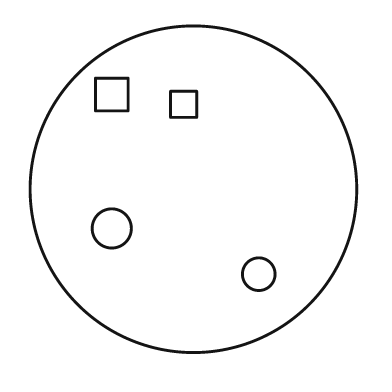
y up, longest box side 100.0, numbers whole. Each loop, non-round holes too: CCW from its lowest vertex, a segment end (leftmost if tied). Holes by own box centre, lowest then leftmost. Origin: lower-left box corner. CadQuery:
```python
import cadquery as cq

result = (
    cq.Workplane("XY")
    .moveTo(50.0, 50.0)
    .circle(50.0)
    .moveTo(70.0, 24.0)
    .circle(5.0)
    .moveTo(25.0, 38.0)
    .circle(6.0)
    .moveTo(43.0, 72.0)
    .lineTo(51.0, 72.0)
    .lineTo(51.0, 80.0)
    .lineTo(43.0, 80.0)
    .close()
    .moveTo(20.0, 74.0)
    .lineTo(30.0, 74.0)
    .lineTo(30.0, 84.0)
    .lineTo(20.0, 84.0)
    .close()
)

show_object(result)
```